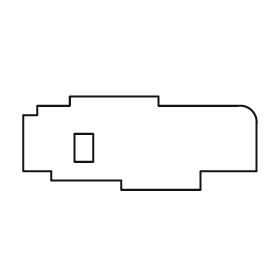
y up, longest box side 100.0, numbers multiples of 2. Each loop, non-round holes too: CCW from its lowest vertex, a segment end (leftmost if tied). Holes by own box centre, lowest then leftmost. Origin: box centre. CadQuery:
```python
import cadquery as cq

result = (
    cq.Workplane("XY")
    .moveTo(-8.0, -20.0)
    .lineTo(26.0, -20.0)
    .lineTo(26.0, -12.0)
    .lineTo(50.0, -12.0)
    .lineTo(50.0, 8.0)
    .threePointArc((48.0, 14.0), (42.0, 16.0))
    .lineTo(8.0, 16.0)
    .lineTo(8.0, 20.0)
    .lineTo(-30.0, 20.0)
    .lineTo(-30.0, 16.0)
    .lineTo(-44.0, 16.0)
    .lineTo(-44.0, 12.0)
    .lineTo(-50.0, 12.0)
    .lineTo(-50.0, -12.0)
    .lineTo(-38.0, -12.0)
    .lineTo(-38.0, -16.0)
    .lineTo(-8.0, -16.0)
    .close()
    .moveTo(-28.0, -8.0)
    .lineTo(-20.0, -8.0)
    .lineTo(-20.0, 4.0)
    .lineTo(-28.0, 4.0)
    .close()
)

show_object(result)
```